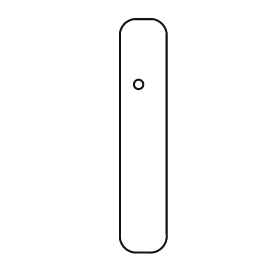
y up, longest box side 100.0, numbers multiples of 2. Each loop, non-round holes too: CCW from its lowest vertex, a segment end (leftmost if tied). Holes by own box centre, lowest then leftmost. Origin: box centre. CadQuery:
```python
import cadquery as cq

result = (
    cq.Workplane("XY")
    .moveTo(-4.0, -50.0)
    .lineTo(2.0, -50.0)
    .threePointArc((8.0, -48.0), (10.0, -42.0))
    .lineTo(10.0, 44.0)
    .threePointArc((8.0, 48.0), (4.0, 50.0))
    .lineTo(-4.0, 50.0)
    .threePointArc((-8.0, 48.0), (-10.0, 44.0))
    .lineTo(-10.0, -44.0)
    .threePointArc((-8.0, -48.0), (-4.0, -50.0))
    .close()
    .moveTo(-2.0, 22.0)
    .circle(2.0)
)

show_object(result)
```